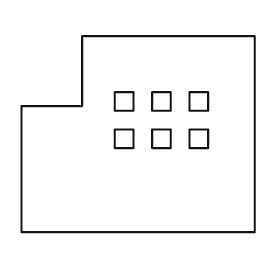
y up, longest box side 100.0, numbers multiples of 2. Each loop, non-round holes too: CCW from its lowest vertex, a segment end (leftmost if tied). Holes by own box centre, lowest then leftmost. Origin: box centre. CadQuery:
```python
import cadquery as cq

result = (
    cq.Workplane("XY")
    .moveTo(-50.0, -42.0)
    .lineTo(50.0, -42.0)
    .lineTo(50.0, 42.0)
    .lineTo(-24.0, 42.0)
    .lineTo(-24.0, 12.0)
    .lineTo(-50.0, 12.0)
    .close()
    .moveTo(-10.0, -6.0)
    .lineTo(-2.0, -6.0)
    .lineTo(-2.0, 2.0)
    .lineTo(-10.0, 2.0)
    .close()
    .moveTo(6.0, -6.0)
    .lineTo(14.0, -6.0)
    .lineTo(14.0, 2.0)
    .lineTo(6.0, 2.0)
    .close()
    .moveTo(22.0, -6.0)
    .lineTo(30.0, -6.0)
    .lineTo(30.0, 2.0)
    .lineTo(22.0, 2.0)
    .close()
    .moveTo(-10.0, 10.0)
    .lineTo(-2.0, 10.0)
    .lineTo(-2.0, 18.0)
    .lineTo(-10.0, 18.0)
    .close()
    .moveTo(6.0, 10.0)
    .lineTo(14.0, 10.0)
    .lineTo(14.0, 18.0)
    .lineTo(6.0, 18.0)
    .close()
    .moveTo(22.0, 10.0)
    .lineTo(30.0, 10.0)
    .lineTo(30.0, 18.0)
    .lineTo(22.0, 18.0)
    .close()
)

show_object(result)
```